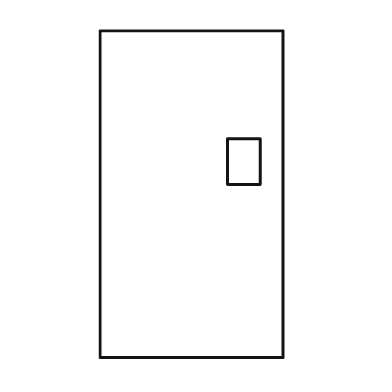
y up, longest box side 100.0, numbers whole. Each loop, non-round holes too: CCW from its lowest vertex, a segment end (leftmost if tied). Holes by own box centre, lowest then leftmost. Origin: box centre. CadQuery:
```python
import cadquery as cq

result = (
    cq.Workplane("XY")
    .moveTo(-28.0, -50.0)
    .lineTo(28.0, -50.0)
    .lineTo(28.0, 50.0)
    .lineTo(-28.0, 50.0)
    .close()
    .moveTo(11.0, 3.0)
    .lineTo(21.0, 3.0)
    .lineTo(21.0, 17.0)
    .lineTo(11.0, 17.0)
    .close()
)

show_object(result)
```